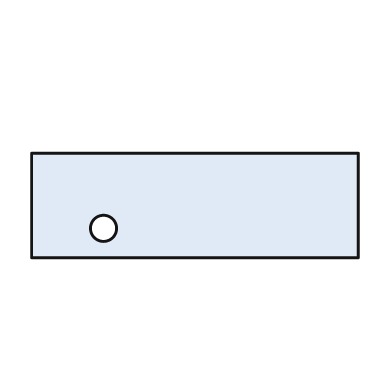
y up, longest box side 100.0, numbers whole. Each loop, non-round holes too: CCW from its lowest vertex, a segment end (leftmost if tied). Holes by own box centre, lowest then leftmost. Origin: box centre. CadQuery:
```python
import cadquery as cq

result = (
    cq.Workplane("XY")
    .moveTo(-50.0, -16.0)
    .lineTo(50.0, -16.0)
    .lineTo(50.0, 16.0)
    .lineTo(-50.0, 16.0)
    .close()
    .moveTo(-28.0, -7.0)
    .circle(4.0)
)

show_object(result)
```